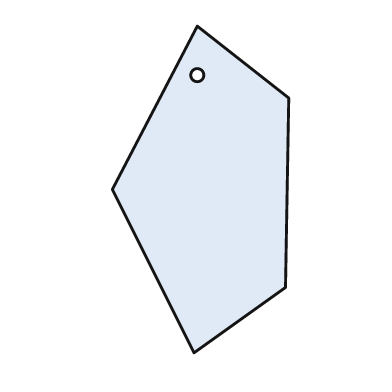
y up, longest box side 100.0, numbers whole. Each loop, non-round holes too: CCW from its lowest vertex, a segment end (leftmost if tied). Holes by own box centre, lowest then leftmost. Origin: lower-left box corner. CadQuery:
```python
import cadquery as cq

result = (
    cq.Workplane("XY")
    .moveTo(25.0, 0.0)
    .lineTo(53.0, 20.0)
    .lineTo(54.0, 78.0)
    .lineTo(26.0, 100.0)
    .lineTo(0.0, 50.0)
    .close()
    .moveTo(26.0, 85.0)
    .circle(2.0)
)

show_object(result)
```